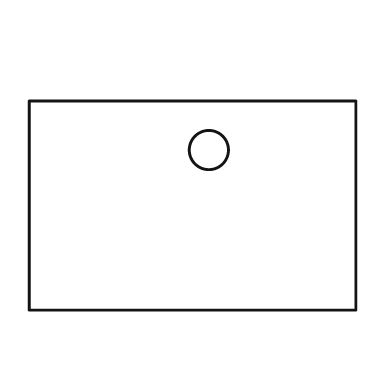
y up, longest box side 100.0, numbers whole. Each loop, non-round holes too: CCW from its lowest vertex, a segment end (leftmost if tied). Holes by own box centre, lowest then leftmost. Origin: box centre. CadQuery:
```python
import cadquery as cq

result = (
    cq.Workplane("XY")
    .moveTo(-50.0, -32.0)
    .lineTo(50.0, -32.0)
    .lineTo(50.0, 32.0)
    .lineTo(-50.0, 32.0)
    .close()
    .moveTo(5.0, 17.0)
    .circle(6.0)
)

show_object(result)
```